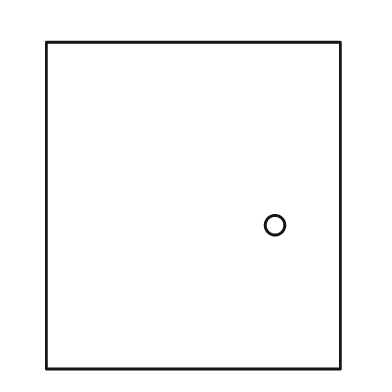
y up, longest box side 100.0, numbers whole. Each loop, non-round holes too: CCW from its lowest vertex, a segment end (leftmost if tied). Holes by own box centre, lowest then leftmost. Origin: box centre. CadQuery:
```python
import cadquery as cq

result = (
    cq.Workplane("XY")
    .moveTo(-45.0, -50.0)
    .lineTo(45.0, -50.0)
    .lineTo(45.0, 50.0)
    .lineTo(-45.0, 50.0)
    .close()
    .moveTo(25.0, -6.0)
    .circle(3.0)
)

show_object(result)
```